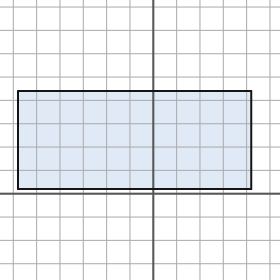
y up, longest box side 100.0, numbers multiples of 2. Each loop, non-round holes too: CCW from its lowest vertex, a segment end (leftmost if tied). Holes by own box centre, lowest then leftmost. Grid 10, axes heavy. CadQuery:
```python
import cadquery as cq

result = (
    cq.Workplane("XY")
    .moveTo(-58.0, 2.0)
    .lineTo(42.0, 2.0)
    .lineTo(42.0, 44.0)
    .lineTo(-58.0, 44.0)
    .close()
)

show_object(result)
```